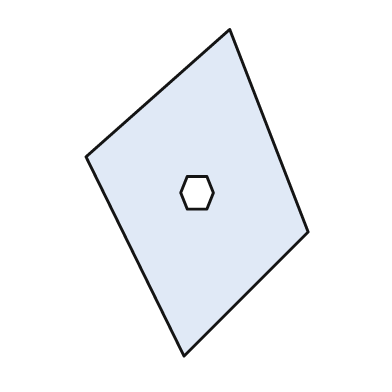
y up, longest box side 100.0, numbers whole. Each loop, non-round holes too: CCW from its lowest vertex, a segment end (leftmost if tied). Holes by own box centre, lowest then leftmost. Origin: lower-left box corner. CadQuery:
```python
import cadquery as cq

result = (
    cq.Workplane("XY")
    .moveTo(30.0, 0.0)
    .lineTo(68.0, 38.0)
    .lineTo(44.0, 100.0)
    .lineTo(0.0, 61.0)
    .close()
    .moveTo(31.0, 45.0)
    .lineTo(37.0, 45.0)
    .lineTo(39.0, 50.0)
    .lineTo(37.0, 55.0)
    .lineTo(31.0, 55.0)
    .lineTo(29.0, 50.0)
    .close()
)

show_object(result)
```